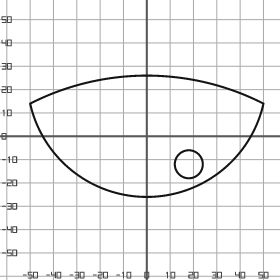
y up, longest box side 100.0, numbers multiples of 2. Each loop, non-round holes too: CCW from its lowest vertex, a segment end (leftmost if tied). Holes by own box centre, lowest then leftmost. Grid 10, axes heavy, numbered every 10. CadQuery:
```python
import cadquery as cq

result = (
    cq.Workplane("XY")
    .moveTo(-50.0, 14.0)
    .threePointArc((0.0, -26.0), (50.0, 14.0))
    .threePointArc((0.0, 26.0), (-50.0, 14.0))
    .close()
    .moveTo(18.0, -12.0)
    .circle(6.0)
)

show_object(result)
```